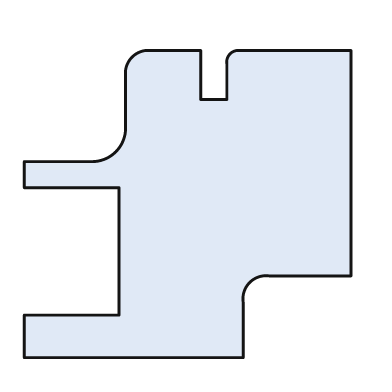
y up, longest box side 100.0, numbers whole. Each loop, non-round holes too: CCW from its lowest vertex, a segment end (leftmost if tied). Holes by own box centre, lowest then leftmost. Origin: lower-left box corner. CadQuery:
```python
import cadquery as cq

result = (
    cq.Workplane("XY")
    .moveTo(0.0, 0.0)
    .lineTo(67.0, 0.0)
    .lineTo(67.0, 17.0)
    .threePointArc((69.0, 23.0), (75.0, 25.0))
    .lineTo(100.0, 25.0)
    .lineTo(100.0, 94.0)
    .lineTo(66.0, 94.0)
    .threePointArc((63.0, 93.0), (62.0, 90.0))
    .lineTo(62.0, 79.0)
    .lineTo(54.0, 79.0)
    .lineTo(54.0, 94.0)
    .lineTo(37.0, 94.0)
    .threePointArc((33.0, 92.0), (31.0, 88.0))
    .lineTo(31.0, 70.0)
    .threePointArc((28.0, 63.0), (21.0, 60.0))
    .lineTo(0.0, 60.0)
    .lineTo(0.0, 52.0)
    .lineTo(29.0, 52.0)
    .lineTo(29.0, 13.0)
    .lineTo(0.0, 13.0)
    .close()
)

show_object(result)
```